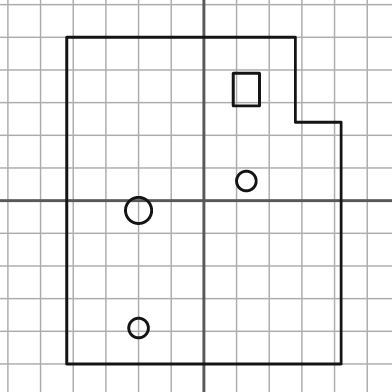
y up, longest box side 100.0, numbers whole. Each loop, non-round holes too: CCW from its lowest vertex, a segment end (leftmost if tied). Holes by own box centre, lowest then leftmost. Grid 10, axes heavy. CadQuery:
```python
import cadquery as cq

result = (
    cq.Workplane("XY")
    .moveTo(-42.0, -50.0)
    .lineTo(42.0, -50.0)
    .lineTo(42.0, 24.0)
    .lineTo(28.0, 24.0)
    .lineTo(28.0, 50.0)
    .lineTo(-42.0, 50.0)
    .close()
    .moveTo(-20.0, -39.0)
    .circle(3.0)
    .moveTo(-20.0, -3.0)
    .circle(4.0)
    .moveTo(13.0, 6.0)
    .circle(3.0)
    .moveTo(9.0, 29.0)
    .lineTo(17.0, 29.0)
    .lineTo(17.0, 39.0)
    .lineTo(9.0, 39.0)
    .close()
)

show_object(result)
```